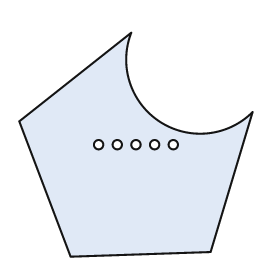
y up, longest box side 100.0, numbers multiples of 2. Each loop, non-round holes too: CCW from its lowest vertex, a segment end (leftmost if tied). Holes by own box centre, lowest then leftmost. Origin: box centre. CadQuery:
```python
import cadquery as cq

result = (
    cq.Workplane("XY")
    .moveTo(-28.0, -48.0)
    .lineTo(32.0, -46.0)
    .lineTo(50.0, 14.0)
    .threePointArc((10.0, 10.0), (-2.0, 48.0))
    .lineTo(-50.0, 10.0)
    .close()
    .moveTo(-16.0, 0.0)
    .circle(2.0)
    .moveTo(-8.0, 0.0)
    .circle(2.0)
    .moveTo(0.0, 0.0)
    .circle(2.0)
    .moveTo(8.0, 0.0)
    .circle(2.0)
    .moveTo(16.0, 0.0)
    .circle(2.0)
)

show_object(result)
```